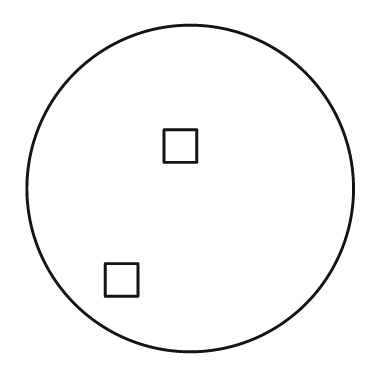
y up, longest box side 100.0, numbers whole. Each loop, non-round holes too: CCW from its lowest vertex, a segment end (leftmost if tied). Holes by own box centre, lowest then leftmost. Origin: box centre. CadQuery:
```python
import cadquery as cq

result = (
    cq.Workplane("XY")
    .moveTo(0.0, 0.0)
    .circle(50.0)
    .moveTo(-26.0, -33.0)
    .lineTo(-16.0, -33.0)
    .lineTo(-16.0, -23.0)
    .lineTo(-26.0, -23.0)
    .close()
    .moveTo(-8.0, 8.0)
    .lineTo(2.0, 8.0)
    .lineTo(2.0, 18.0)
    .lineTo(-8.0, 18.0)
    .close()
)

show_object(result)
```